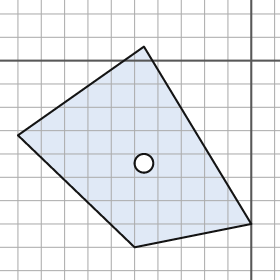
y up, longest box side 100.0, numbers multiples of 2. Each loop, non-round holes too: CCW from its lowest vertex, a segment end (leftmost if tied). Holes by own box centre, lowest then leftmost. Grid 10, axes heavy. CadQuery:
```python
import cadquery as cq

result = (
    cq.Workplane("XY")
    .moveTo(-50.0, -80.0)
    .lineTo(0.0, -70.0)
    .lineTo(-46.0, 6.0)
    .lineTo(-100.0, -32.0)
    .close()
    .moveTo(-46.0, -44.0)
    .circle(4.0)
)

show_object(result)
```